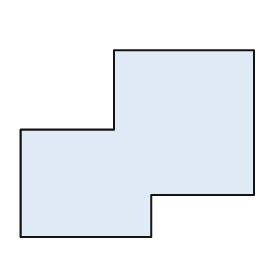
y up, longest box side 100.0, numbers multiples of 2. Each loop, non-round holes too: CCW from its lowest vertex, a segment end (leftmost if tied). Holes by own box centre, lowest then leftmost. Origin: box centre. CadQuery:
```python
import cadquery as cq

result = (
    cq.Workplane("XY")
    .moveTo(-50.0, -40.0)
    .lineTo(6.0, -40.0)
    .lineTo(6.0, -22.0)
    .lineTo(50.0, -22.0)
    .lineTo(50.0, 40.0)
    .lineTo(-10.0, 40.0)
    .lineTo(-10.0, 6.0)
    .lineTo(-50.0, 6.0)
    .close()
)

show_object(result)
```